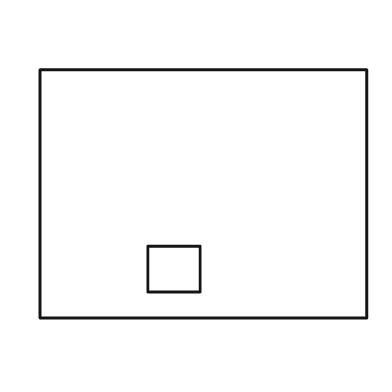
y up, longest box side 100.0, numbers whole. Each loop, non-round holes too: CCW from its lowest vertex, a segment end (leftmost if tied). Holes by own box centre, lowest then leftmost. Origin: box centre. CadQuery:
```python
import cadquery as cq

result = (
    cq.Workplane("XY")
    .moveTo(-50.0, -38.0)
    .lineTo(50.0, -38.0)
    .lineTo(50.0, 38.0)
    .lineTo(-50.0, 38.0)
    .close()
    .moveTo(-17.0, -30.0)
    .lineTo(-1.0, -30.0)
    .lineTo(-1.0, -16.0)
    .lineTo(-17.0, -16.0)
    .close()
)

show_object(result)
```